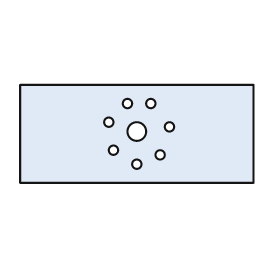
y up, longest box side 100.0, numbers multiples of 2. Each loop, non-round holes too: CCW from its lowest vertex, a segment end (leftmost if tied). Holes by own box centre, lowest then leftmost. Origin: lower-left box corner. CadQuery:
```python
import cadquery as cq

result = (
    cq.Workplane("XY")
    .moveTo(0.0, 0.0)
    .lineTo(100.0, 0.0)
    .lineTo(100.0, 42.0)
    .lineTo(0.0, 42.0)
    .close()
    .moveTo(50.0, 8.0)
    .circle(2.0)
    .moveTo(60.0, 12.0)
    .circle(2.0)
    .moveTo(40.0, 14.0)
    .circle(2.0)
    .moveTo(50.0, 22.0)
    .circle(4.0)
    .moveTo(64.0, 24.0)
    .circle(2.0)
    .moveTo(38.0, 26.0)
    .circle(2.0)
    .moveTo(46.0, 34.0)
    .circle(2.0)
    .moveTo(56.0, 34.0)
    .circle(2.0)
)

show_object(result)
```